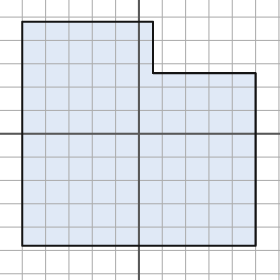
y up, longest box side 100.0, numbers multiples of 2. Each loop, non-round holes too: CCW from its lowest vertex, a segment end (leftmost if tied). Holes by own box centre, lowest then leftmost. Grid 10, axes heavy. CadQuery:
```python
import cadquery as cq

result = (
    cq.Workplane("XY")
    .moveTo(-50.0, -48.0)
    .lineTo(50.0, -48.0)
    .lineTo(50.0, 26.0)
    .lineTo(6.0, 26.0)
    .lineTo(6.0, 48.0)
    .lineTo(-50.0, 48.0)
    .close()
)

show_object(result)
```